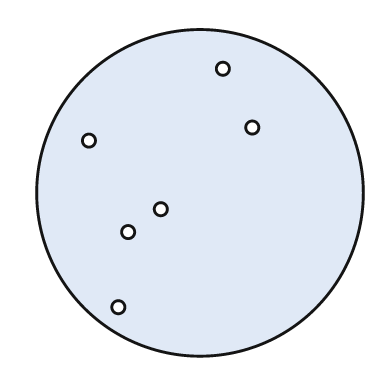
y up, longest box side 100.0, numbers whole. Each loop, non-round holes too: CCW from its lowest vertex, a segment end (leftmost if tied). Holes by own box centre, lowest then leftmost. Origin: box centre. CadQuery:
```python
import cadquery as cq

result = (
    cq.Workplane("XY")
    .moveTo(0.0, 0.0)
    .circle(50.0)
    .moveTo(-25.0, -35.0)
    .circle(2.0)
    .moveTo(-22.0, -12.0)
    .circle(2.0)
    .moveTo(-12.0, -5.0)
    .circle(2.0)
    .moveTo(-34.0, 16.0)
    .circle(2.0)
    .moveTo(16.0, 20.0)
    .circle(2.0)
    .moveTo(7.0, 38.0)
    .circle(2.0)
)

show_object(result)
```